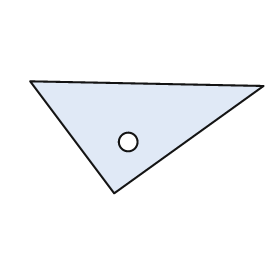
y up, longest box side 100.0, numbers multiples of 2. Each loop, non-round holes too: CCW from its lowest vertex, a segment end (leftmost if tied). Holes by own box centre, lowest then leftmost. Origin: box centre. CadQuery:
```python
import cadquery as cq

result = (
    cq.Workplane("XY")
    .moveTo(-14.0, -24.0)
    .lineTo(50.0, 22.0)
    .lineTo(-50.0, 24.0)
    .close()
    .moveTo(-8.0, -2.0)
    .circle(4.0)
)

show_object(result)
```